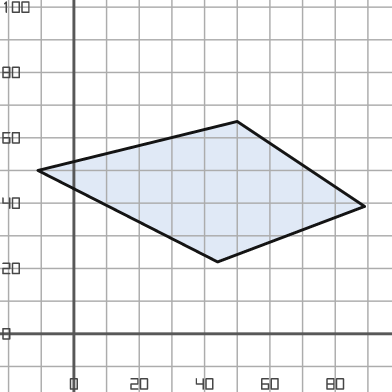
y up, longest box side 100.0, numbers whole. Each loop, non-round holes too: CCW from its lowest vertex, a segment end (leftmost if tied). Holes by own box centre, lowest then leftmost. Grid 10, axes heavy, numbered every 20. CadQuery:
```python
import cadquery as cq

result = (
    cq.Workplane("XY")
    .moveTo(44.0, 22.0)
    .lineTo(89.0, 39.0)
    .lineTo(50.0, 65.0)
    .lineTo(-11.0, 50.0)
    .close()
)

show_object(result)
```